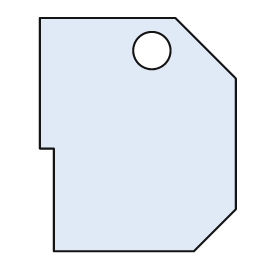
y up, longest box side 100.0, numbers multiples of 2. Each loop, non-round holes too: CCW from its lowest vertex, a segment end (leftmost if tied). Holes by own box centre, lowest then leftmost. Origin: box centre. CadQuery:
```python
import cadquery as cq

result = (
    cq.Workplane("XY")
    .moveTo(-36.0, -50.0)
    .lineTo(24.0, -50.0)
    .lineTo(42.0, -32.0)
    .lineTo(42.0, 24.0)
    .lineTo(16.0, 50.0)
    .lineTo(-42.0, 50.0)
    .lineTo(-42.0, -6.0)
    .lineTo(-36.0, -6.0)
    .close()
    .moveTo(6.0, 36.0)
    .circle(8.0)
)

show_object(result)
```